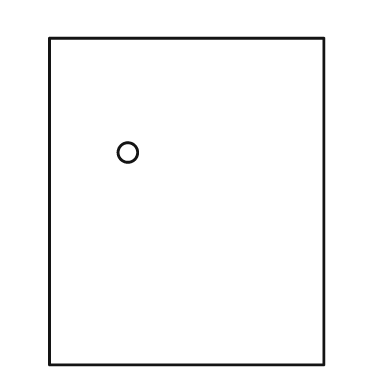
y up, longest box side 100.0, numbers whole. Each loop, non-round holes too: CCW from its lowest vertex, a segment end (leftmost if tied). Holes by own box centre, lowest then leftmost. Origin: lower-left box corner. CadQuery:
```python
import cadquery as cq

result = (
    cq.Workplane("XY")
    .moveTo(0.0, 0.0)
    .lineTo(84.0, 0.0)
    .lineTo(84.0, 100.0)
    .lineTo(0.0, 100.0)
    .close()
    .moveTo(24.0, 65.0)
    .circle(3.0)
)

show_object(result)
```